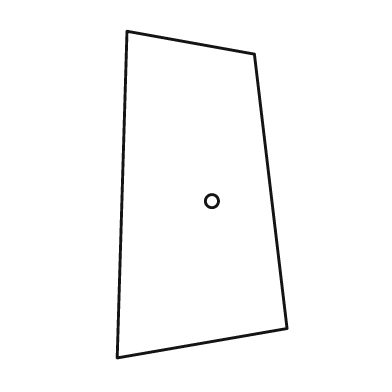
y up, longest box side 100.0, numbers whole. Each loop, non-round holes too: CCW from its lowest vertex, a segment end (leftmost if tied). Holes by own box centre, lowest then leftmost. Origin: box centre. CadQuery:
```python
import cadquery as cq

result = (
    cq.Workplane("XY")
    .moveTo(-26.0, -50.0)
    .lineTo(26.0, -41.0)
    .lineTo(16.0, 43.0)
    .lineTo(-23.0, 50.0)
    .close()
    .moveTo(3.0, -2.0)
    .circle(2.0)
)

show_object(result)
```